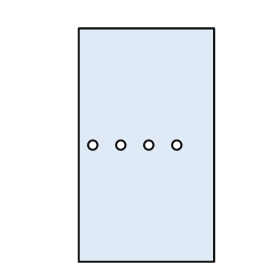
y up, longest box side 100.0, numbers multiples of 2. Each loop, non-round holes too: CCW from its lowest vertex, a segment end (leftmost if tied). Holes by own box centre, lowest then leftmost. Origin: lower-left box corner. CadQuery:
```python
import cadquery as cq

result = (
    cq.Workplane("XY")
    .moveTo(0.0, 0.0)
    .lineTo(58.0, 0.0)
    .lineTo(58.0, 100.0)
    .lineTo(0.0, 100.0)
    .close()
    .moveTo(6.0, 50.0)
    .circle(2.0)
    .moveTo(18.0, 50.0)
    .circle(2.0)
    .moveTo(30.0, 50.0)
    .circle(2.0)
    .moveTo(42.0, 50.0)
    .circle(2.0)
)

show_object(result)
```